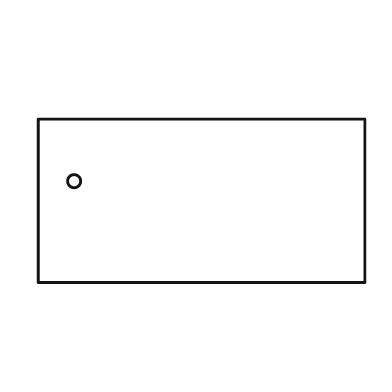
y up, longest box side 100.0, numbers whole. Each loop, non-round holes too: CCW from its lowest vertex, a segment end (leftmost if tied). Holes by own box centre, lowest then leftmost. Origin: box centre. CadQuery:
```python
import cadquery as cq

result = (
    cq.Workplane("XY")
    .moveTo(-50.0, -25.0)
    .lineTo(50.0, -25.0)
    .lineTo(50.0, 25.0)
    .lineTo(-50.0, 25.0)
    .close()
    .moveTo(-39.0, 6.0)
    .circle(2.0)
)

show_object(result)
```